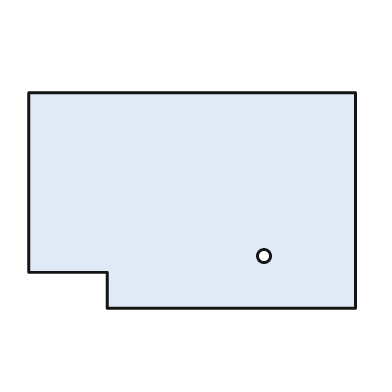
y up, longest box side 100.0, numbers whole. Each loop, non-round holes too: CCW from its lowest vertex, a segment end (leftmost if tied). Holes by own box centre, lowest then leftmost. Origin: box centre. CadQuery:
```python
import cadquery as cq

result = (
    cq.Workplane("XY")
    .moveTo(-26.0, -33.0)
    .lineTo(50.0, -33.0)
    .lineTo(50.0, 33.0)
    .lineTo(-50.0, 33.0)
    .lineTo(-50.0, -22.0)
    .lineTo(-26.0, -22.0)
    .close()
    .moveTo(22.0, -17.0)
    .circle(2.0)
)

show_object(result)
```